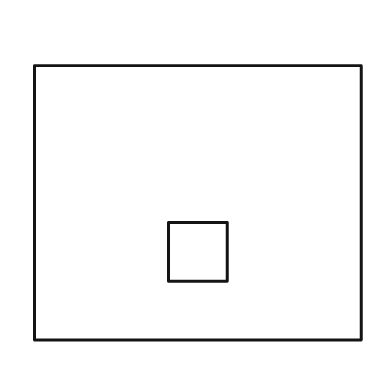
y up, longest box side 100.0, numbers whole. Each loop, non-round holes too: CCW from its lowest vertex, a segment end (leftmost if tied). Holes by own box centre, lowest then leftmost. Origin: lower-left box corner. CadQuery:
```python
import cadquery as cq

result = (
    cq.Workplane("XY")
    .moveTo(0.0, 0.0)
    .lineTo(100.0, 0.0)
    .lineTo(100.0, 84.0)
    .lineTo(0.0, 84.0)
    .close()
    .moveTo(41.0, 18.0)
    .lineTo(59.0, 18.0)
    .lineTo(59.0, 36.0)
    .lineTo(41.0, 36.0)
    .close()
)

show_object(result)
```